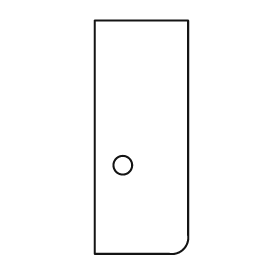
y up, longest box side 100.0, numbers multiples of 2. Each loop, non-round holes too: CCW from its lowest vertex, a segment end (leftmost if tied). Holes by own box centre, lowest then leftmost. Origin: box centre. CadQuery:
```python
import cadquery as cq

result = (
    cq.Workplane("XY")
    .moveTo(-20.0, -50.0)
    .lineTo(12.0, -50.0)
    .threePointArc((18.0, -48.0), (20.0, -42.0))
    .lineTo(20.0, 50.0)
    .lineTo(-20.0, 50.0)
    .close()
    .moveTo(-8.0, -12.0)
    .circle(4.0)
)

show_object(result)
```